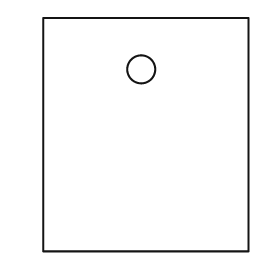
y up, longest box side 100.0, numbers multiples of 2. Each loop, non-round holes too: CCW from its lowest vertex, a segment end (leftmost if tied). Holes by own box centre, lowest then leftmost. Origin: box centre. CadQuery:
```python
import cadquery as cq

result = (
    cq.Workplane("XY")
    .moveTo(-44.0, -50.0)
    .lineTo(44.0, -50.0)
    .lineTo(44.0, 50.0)
    .lineTo(-44.0, 50.0)
    .close()
    .moveTo(-2.0, 28.0)
    .circle(6.0)
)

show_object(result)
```